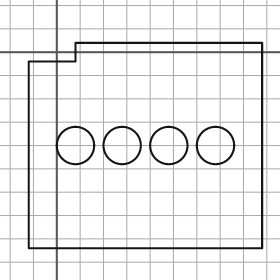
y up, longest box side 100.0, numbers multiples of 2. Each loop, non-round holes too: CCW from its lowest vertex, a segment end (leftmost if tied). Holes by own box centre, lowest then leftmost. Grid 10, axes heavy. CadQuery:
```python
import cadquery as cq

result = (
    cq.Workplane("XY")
    .moveTo(-12.0, -84.0)
    .lineTo(88.0, -84.0)
    .lineTo(88.0, 4.0)
    .lineTo(8.0, 4.0)
    .lineTo(8.0, -4.0)
    .lineTo(-12.0, -4.0)
    .close()
    .moveTo(8.0, -40.0)
    .circle(8.0)
    .moveTo(28.0, -40.0)
    .circle(8.0)
    .moveTo(48.0, -40.0)
    .circle(8.0)
    .moveTo(68.0, -40.0)
    .circle(8.0)
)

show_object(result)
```